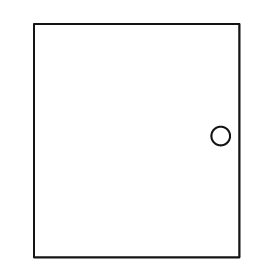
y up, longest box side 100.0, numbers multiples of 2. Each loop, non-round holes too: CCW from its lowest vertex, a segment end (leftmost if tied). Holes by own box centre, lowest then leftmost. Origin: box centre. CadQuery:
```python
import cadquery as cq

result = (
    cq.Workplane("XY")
    .moveTo(-44.0, -50.0)
    .lineTo(44.0, -50.0)
    .lineTo(44.0, 50.0)
    .lineTo(-44.0, 50.0)
    .close()
    .moveTo(36.0, 2.0)
    .circle(4.0)
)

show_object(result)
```